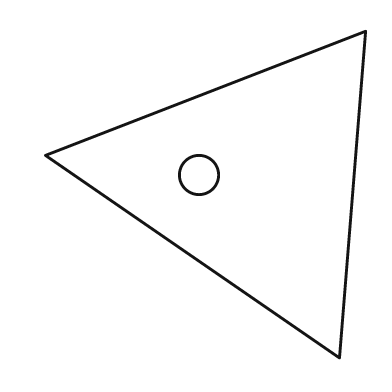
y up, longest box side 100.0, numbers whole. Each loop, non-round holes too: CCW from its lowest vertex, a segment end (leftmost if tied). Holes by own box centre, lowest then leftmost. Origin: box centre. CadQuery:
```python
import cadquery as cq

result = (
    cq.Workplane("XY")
    .moveTo(41.0, -50.0)
    .lineTo(49.0, 50.0)
    .lineTo(-49.0, 12.0)
    .close()
    .moveTo(-2.0, 6.0)
    .circle(6.0)
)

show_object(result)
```